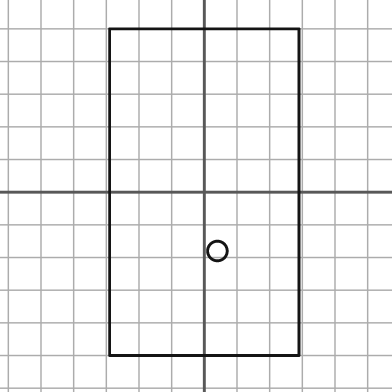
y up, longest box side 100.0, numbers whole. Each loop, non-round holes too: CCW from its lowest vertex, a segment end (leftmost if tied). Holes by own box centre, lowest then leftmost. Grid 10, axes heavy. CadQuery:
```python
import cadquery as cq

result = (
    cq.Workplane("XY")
    .moveTo(-29.0, -50.0)
    .lineTo(29.0, -50.0)
    .lineTo(29.0, 50.0)
    .lineTo(-29.0, 50.0)
    .close()
    .moveTo(4.0, -18.0)
    .circle(3.0)
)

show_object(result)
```